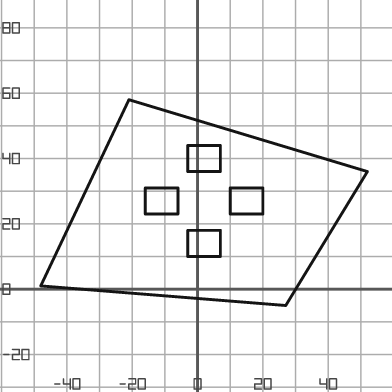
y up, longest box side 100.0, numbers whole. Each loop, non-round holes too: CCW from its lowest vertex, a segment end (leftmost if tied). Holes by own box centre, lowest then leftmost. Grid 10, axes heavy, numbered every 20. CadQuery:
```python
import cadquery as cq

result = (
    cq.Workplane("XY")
    .moveTo(27.0, -5.0)
    .lineTo(52.0, 36.0)
    .lineTo(-21.0, 58.0)
    .lineTo(-48.0, 1.0)
    .close()
    .moveTo(-3.0, 10.0)
    .lineTo(7.0, 10.0)
    .lineTo(7.0, 18.0)
    .lineTo(-3.0, 18.0)
    .close()
    .moveTo(-16.0, 23.0)
    .lineTo(-6.0, 23.0)
    .lineTo(-6.0, 31.0)
    .lineTo(-16.0, 31.0)
    .close()
    .moveTo(10.0, 23.0)
    .lineTo(20.0, 23.0)
    .lineTo(20.0, 31.0)
    .lineTo(10.0, 31.0)
    .close()
    .moveTo(-3.0, 36.0)
    .lineTo(7.0, 36.0)
    .lineTo(7.0, 44.0)
    .lineTo(-3.0, 44.0)
    .close()
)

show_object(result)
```